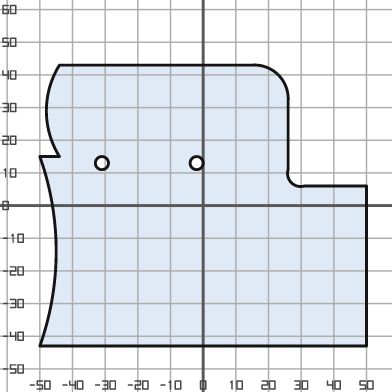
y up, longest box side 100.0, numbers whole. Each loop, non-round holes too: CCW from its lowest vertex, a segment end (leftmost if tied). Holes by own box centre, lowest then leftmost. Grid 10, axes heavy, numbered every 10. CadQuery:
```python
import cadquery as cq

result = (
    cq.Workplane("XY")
    .moveTo(-50.0, -43.0)
    .lineTo(50.0, -43.0)
    .lineTo(50.0, 6.0)
    .lineTo(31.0, 6.0)
    .threePointArc((27.0, 7.0), (26.0, 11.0))
    .lineTo(26.0, 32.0)
    .threePointArc((23.0, 40.0), (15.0, 43.0))
    .lineTo(-44.0, 43.0)
    .threePointArc((-48.0, 29.0), (-44.0, 15.0))
    .lineTo(-50.0, 15.0)
    .threePointArc((-45.0, -14.0), (-50.0, -43.0))
    .close()
    .moveTo(-31.0, 13.0)
    .circle(2.0)
    .moveTo(-2.0, 13.0)
    .circle(2.0)
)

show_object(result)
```